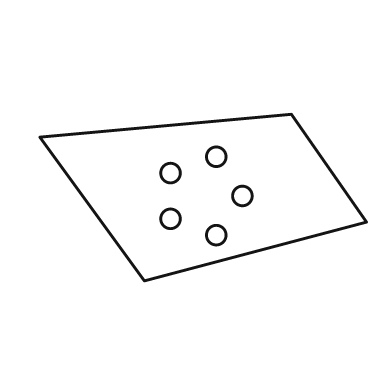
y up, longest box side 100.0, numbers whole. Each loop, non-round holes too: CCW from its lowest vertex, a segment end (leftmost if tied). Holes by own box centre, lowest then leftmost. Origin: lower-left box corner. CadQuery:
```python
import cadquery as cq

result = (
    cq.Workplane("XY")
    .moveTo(32.0, 0.0)
    .lineTo(100.0, 18.0)
    .lineTo(77.0, 51.0)
    .lineTo(0.0, 44.0)
    .close()
    .moveTo(54.0, 14.0)
    .circle(3.0)
    .moveTo(40.0, 19.0)
    .circle(3.0)
    .moveTo(62.0, 26.0)
    .circle(3.0)
    .moveTo(40.0, 33.0)
    .circle(3.0)
    .moveTo(54.0, 38.0)
    .circle(3.0)
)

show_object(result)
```